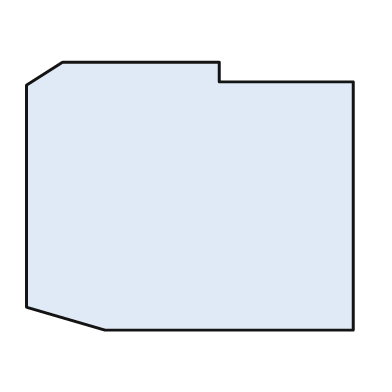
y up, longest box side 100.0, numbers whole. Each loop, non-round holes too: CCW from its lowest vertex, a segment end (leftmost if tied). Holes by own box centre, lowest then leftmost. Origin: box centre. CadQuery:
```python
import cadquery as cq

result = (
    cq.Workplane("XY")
    .moveTo(-26.0, -41.0)
    .lineTo(50.0, -41.0)
    .lineTo(50.0, 35.0)
    .lineTo(9.0, 35.0)
    .lineTo(9.0, 41.0)
    .lineTo(-39.0, 41.0)
    .lineTo(-50.0, 34.0)
    .lineTo(-50.0, -34.0)
    .close()
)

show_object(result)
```